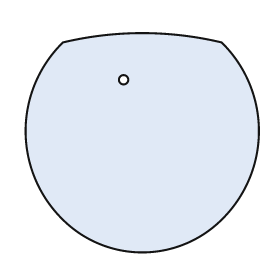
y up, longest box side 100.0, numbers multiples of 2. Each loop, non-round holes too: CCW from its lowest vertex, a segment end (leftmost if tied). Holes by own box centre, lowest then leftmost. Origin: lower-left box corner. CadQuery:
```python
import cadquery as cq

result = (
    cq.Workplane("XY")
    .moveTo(16.0, 14.0)
    .threePointArc((50.0, 0.0), (84.0, 14.0))
    .threePointArc((100.0, 52.0), (84.0, 90.0))
    .threePointArc((50.0, 94.0), (16.0, 90.0))
    .threePointArc((0.0, 52.0), (16.0, 14.0))
    .close()
    .moveTo(42.0, 74.0)
    .circle(2.0)
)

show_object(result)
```